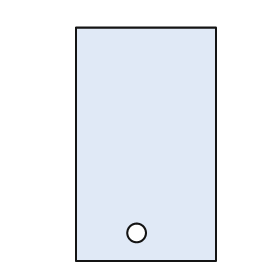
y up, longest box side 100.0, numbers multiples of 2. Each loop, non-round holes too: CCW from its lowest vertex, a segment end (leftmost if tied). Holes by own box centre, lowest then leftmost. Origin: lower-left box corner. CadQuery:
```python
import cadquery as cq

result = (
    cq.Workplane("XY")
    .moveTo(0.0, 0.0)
    .lineTo(60.0, 0.0)
    .lineTo(60.0, 100.0)
    .lineTo(0.0, 100.0)
    .close()
    .moveTo(26.0, 12.0)
    .circle(4.0)
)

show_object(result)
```